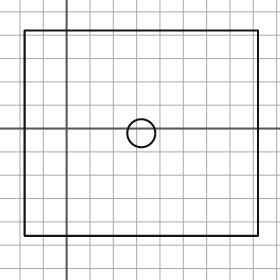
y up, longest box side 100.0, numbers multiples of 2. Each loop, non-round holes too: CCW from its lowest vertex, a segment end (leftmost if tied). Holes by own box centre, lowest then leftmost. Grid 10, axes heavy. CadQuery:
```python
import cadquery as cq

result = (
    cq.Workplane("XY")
    .moveTo(-18.0, -46.0)
    .lineTo(82.0, -46.0)
    .lineTo(82.0, 42.0)
    .lineTo(-18.0, 42.0)
    .close()
    .moveTo(32.0, -2.0)
    .circle(6.0)
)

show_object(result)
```